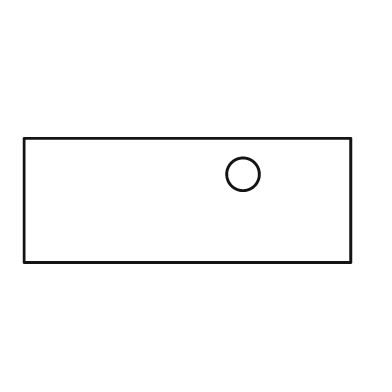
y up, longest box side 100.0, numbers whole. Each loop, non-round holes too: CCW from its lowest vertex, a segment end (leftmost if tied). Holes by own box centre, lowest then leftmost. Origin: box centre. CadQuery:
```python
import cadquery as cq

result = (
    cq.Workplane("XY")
    .moveTo(-50.0, -19.0)
    .lineTo(50.0, -19.0)
    .lineTo(50.0, 19.0)
    .lineTo(-50.0, 19.0)
    .close()
    .moveTo(17.0, 8.0)
    .circle(5.0)
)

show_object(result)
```